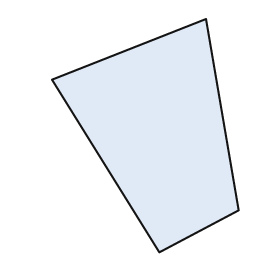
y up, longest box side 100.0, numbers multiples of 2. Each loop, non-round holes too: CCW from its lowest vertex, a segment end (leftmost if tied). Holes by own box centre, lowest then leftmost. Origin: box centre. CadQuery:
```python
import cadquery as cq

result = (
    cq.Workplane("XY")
    .moveTo(6.0, -50.0)
    .lineTo(40.0, -32.0)
    .lineTo(26.0, 50.0)
    .lineTo(-40.0, 24.0)
    .close()
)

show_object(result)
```